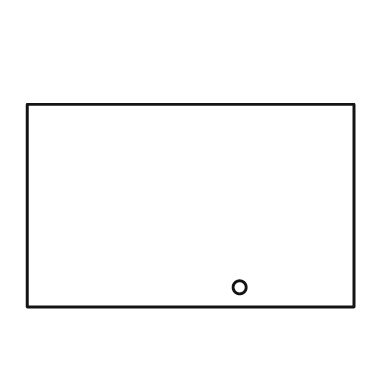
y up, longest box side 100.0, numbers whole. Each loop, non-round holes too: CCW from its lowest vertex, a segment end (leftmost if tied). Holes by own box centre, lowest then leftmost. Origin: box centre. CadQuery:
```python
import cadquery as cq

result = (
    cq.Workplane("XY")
    .moveTo(-50.0, -31.0)
    .lineTo(50.0, -31.0)
    .lineTo(50.0, 31.0)
    .lineTo(-50.0, 31.0)
    .close()
    .moveTo(15.0, -25.0)
    .circle(2.0)
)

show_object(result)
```